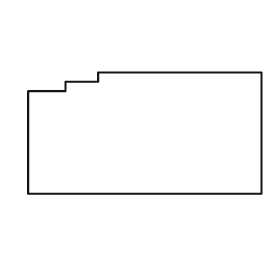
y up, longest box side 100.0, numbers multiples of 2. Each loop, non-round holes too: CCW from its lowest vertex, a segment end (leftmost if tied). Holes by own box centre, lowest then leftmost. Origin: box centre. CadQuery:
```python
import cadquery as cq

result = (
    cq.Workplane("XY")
    .moveTo(-50.0, -26.0)
    .lineTo(50.0, -26.0)
    .lineTo(50.0, 26.0)
    .lineTo(-20.0, 26.0)
    .lineTo(-20.0, 22.0)
    .lineTo(-34.0, 22.0)
    .lineTo(-34.0, 18.0)
    .lineTo(-50.0, 18.0)
    .close()
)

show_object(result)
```